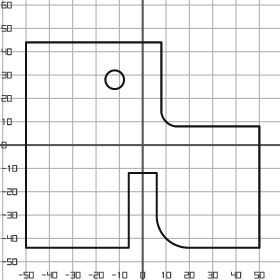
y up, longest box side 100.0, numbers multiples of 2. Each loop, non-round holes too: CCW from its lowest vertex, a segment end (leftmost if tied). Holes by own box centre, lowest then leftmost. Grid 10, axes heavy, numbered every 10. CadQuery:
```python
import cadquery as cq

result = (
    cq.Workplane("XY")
    .moveTo(-50.0, -44.0)
    .lineTo(-6.0, -44.0)
    .lineTo(-6.0, -12.0)
    .lineTo(6.0, -12.0)
    .lineTo(6.0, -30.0)
    .threePointArc((10.0, -40.0), (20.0, -44.0))
    .lineTo(50.0, -44.0)
    .lineTo(50.0, 8.0)
    .lineTo(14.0, 8.0)
    .threePointArc((10.0, 10.0), (8.0, 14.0))
    .lineTo(8.0, 44.0)
    .lineTo(-50.0, 44.0)
    .close()
    .moveTo(-12.0, 28.0)
    .circle(4.0)
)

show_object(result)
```